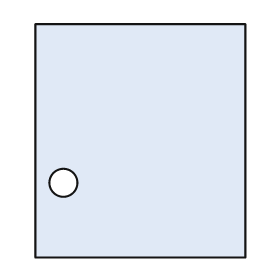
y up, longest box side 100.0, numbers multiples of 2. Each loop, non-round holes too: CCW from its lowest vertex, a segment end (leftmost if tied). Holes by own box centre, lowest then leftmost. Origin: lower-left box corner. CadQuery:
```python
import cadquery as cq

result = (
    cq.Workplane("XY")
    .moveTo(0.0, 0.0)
    .lineTo(90.0, 0.0)
    .lineTo(90.0, 100.0)
    .lineTo(0.0, 100.0)
    .close()
    .moveTo(12.0, 32.0)
    .circle(6.0)
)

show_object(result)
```